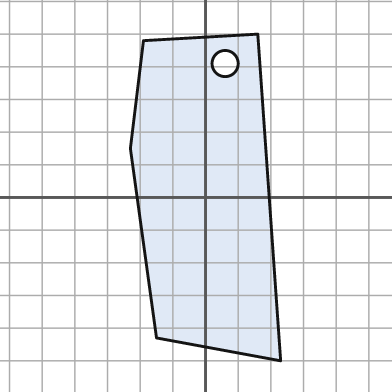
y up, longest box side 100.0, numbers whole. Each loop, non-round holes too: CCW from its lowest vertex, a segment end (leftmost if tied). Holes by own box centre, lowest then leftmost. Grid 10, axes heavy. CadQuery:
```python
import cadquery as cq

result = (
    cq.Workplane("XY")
    .moveTo(23.0, -50.0)
    .lineTo(16.0, 50.0)
    .lineTo(-19.0, 48.0)
    .lineTo(-23.0, 15.0)
    .lineTo(-15.0, -43.0)
    .close()
    .moveTo(6.0, 41.0)
    .circle(4.0)
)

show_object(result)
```